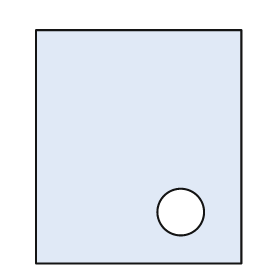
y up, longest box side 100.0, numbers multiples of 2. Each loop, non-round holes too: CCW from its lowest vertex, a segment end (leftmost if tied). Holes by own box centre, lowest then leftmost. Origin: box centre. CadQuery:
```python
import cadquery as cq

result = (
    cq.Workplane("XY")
    .moveTo(-44.0, -50.0)
    .lineTo(44.0, -50.0)
    .lineTo(44.0, 50.0)
    .lineTo(-44.0, 50.0)
    .close()
    .moveTo(18.0, -28.0)
    .circle(10.0)
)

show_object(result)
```